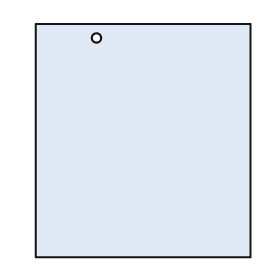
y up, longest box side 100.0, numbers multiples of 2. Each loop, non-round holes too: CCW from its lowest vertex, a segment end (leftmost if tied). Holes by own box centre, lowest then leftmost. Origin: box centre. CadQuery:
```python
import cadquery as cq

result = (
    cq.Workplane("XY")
    .moveTo(-46.0, -50.0)
    .lineTo(46.0, -50.0)
    .lineTo(46.0, 50.0)
    .lineTo(-46.0, 50.0)
    .close()
    .moveTo(-20.0, 44.0)
    .circle(2.0)
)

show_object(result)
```